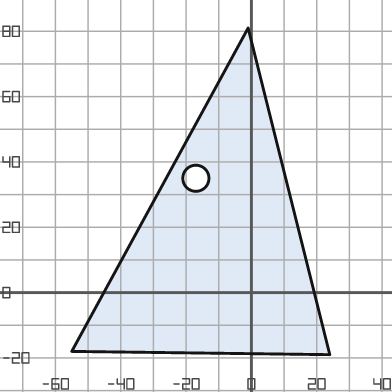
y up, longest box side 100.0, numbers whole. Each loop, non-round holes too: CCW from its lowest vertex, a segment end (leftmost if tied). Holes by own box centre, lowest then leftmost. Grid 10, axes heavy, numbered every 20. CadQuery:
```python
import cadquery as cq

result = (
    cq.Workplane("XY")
    .moveTo(24.0, -19.0)
    .lineTo(-1.0, 81.0)
    .lineTo(-55.0, -18.0)
    .close()
    .moveTo(-17.0, 35.0)
    .circle(4.0)
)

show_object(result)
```